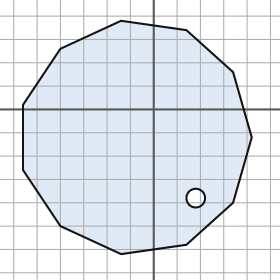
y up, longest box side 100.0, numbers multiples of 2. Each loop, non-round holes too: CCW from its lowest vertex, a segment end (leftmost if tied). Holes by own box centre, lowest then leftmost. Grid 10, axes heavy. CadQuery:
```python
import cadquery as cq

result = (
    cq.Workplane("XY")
    .moveTo(-14.0, -62.0)
    .lineTo(14.0, -58.0)
    .lineTo(34.0, -40.0)
    .lineTo(42.0, -12.0)
    .lineTo(34.0, 16.0)
    .lineTo(14.0, 34.0)
    .lineTo(-14.0, 38.0)
    .lineTo(-40.0, 26.0)
    .lineTo(-56.0, 2.0)
    .lineTo(-56.0, -26.0)
    .lineTo(-40.0, -50.0)
    .close()
    .moveTo(18.0, -38.0)
    .circle(4.0)
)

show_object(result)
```